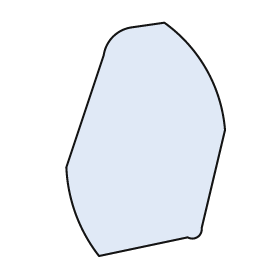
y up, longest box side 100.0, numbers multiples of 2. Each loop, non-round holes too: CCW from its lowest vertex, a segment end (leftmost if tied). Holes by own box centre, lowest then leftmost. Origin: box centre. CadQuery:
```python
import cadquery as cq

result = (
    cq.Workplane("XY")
    .moveTo(-20.0, -50.0)
    .lineTo(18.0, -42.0)
    .threePointArc((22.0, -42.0), (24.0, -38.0))
    .lineTo(34.0, 4.0)
    .threePointArc((26.0, 30.0), (8.0, 50.0))
    .lineTo(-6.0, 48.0)
    .threePointArc((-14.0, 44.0), (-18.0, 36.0))
    .lineTo(-34.0, -12.0)
    .threePointArc((-30.0, -32.0), (-20.0, -50.0))
    .close()
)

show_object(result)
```